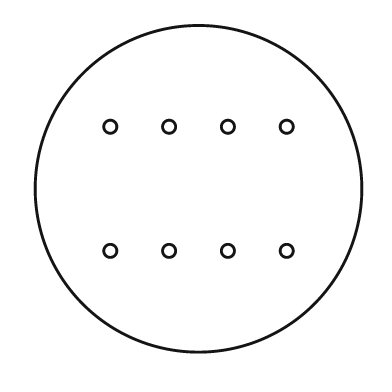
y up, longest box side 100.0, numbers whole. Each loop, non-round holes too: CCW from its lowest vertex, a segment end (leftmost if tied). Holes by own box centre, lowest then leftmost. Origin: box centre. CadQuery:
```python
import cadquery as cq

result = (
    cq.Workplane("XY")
    .moveTo(0.0, 0.0)
    .circle(50.0)
    .moveTo(-27.0, -19.0)
    .circle(2.0)
    .moveTo(-9.0, -19.0)
    .circle(2.0)
    .moveTo(9.0, -19.0)
    .circle(2.0)
    .moveTo(27.0, -19.0)
    .circle(2.0)
    .moveTo(-27.0, 19.0)
    .circle(2.0)
    .moveTo(-9.0, 19.0)
    .circle(2.0)
    .moveTo(9.0, 19.0)
    .circle(2.0)
    .moveTo(27.0, 19.0)
    .circle(2.0)
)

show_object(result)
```